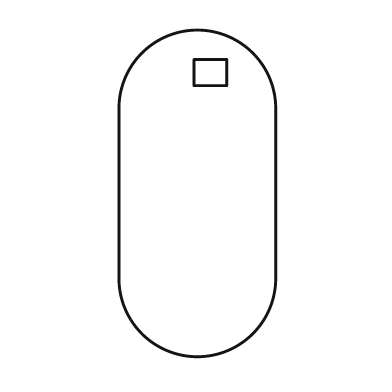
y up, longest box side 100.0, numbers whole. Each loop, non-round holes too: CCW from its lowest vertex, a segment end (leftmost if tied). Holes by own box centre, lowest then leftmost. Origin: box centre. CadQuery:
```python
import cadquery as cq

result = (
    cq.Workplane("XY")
    .moveTo(-24.0, -26.0)
    .threePointArc((0.0, -50.0), (24.0, -26.0))
    .lineTo(24.0, 26.0)
    .threePointArc((0.0, 50.0), (-24.0, 26.0))
    .close()
    .moveTo(-1.0, 33.0)
    .lineTo(9.0, 33.0)
    .lineTo(9.0, 41.0)
    .lineTo(-1.0, 41.0)
    .close()
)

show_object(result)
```